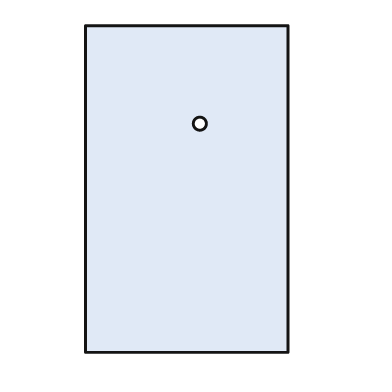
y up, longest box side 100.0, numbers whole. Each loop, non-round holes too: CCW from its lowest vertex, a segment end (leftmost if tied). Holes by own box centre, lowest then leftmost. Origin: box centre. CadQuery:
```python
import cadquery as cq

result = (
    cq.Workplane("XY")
    .moveTo(-31.0, -50.0)
    .lineTo(31.0, -50.0)
    .lineTo(31.0, 50.0)
    .lineTo(-31.0, 50.0)
    .close()
    .moveTo(4.0, 20.0)
    .circle(2.0)
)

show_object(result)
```